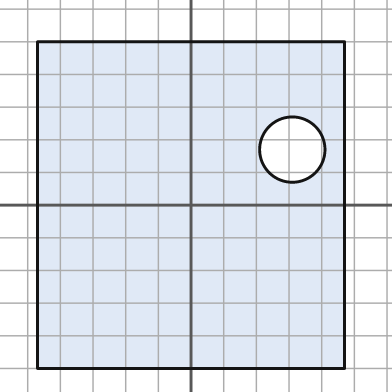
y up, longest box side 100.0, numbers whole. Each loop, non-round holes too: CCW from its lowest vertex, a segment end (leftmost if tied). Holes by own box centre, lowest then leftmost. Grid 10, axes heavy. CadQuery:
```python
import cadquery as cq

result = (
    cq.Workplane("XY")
    .moveTo(-47.0, -50.0)
    .lineTo(47.0, -50.0)
    .lineTo(47.0, 50.0)
    .lineTo(-47.0, 50.0)
    .close()
    .moveTo(31.0, 17.0)
    .circle(10.0)
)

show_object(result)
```